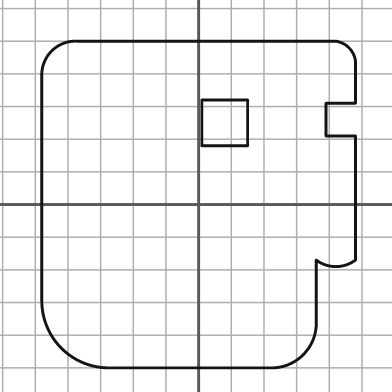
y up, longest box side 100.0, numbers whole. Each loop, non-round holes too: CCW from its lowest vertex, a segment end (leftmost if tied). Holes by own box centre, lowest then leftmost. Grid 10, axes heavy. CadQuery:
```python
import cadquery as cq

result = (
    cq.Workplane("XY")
    .moveTo(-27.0, -50.0)
    .lineTo(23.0, -50.0)
    .threePointArc((32.0, -46.0), (36.0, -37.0))
    .lineTo(36.0, -17.0)
    .threePointArc((42.0, -19.0), (48.0, -17.0))
    .lineTo(48.0, 21.0)
    .lineTo(39.0, 21.0)
    .lineTo(39.0, 31.0)
    .lineTo(48.0, 31.0)
    .lineTo(48.0, 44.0)
    .threePointArc((46.0, 48.0), (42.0, 50.0))
    .lineTo(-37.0, 50.0)
    .threePointArc((-45.0, 47.0), (-48.0, 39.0))
    .lineTo(-48.0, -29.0)
    .threePointArc((-42.0, -44.0), (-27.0, -50.0))
    .close()
    .moveTo(1.0, 18.0)
    .lineTo(15.0, 18.0)
    .lineTo(15.0, 32.0)
    .lineTo(1.0, 32.0)
    .close()
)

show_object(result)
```